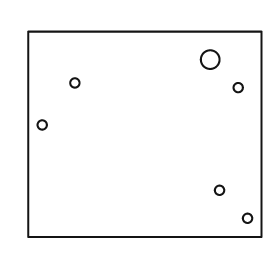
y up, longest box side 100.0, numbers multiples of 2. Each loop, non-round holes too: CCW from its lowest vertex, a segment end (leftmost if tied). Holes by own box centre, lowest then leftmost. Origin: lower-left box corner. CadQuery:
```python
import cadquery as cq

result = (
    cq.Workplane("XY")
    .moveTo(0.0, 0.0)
    .lineTo(100.0, 0.0)
    .lineTo(100.0, 88.0)
    .lineTo(0.0, 88.0)
    .close()
    .moveTo(94.0, 8.0)
    .circle(2.0)
    .moveTo(82.0, 20.0)
    .circle(2.0)
    .moveTo(6.0, 48.0)
    .circle(2.0)
    .moveTo(90.0, 64.0)
    .circle(2.0)
    .moveTo(20.0, 66.0)
    .circle(2.0)
    .moveTo(78.0, 76.0)
    .circle(4.0)
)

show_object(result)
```